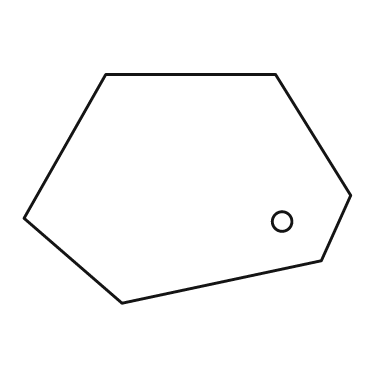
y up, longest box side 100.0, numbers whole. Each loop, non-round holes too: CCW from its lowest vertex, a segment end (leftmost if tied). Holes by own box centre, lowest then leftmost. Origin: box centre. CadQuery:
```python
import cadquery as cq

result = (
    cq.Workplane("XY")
    .moveTo(-20.0, -35.0)
    .lineTo(41.0, -22.0)
    .lineTo(50.0, -2.0)
    .lineTo(27.0, 35.0)
    .lineTo(-25.0, 35.0)
    .lineTo(-50.0, -9.0)
    .close()
    .moveTo(29.0, -10.0)
    .circle(3.0)
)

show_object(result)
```